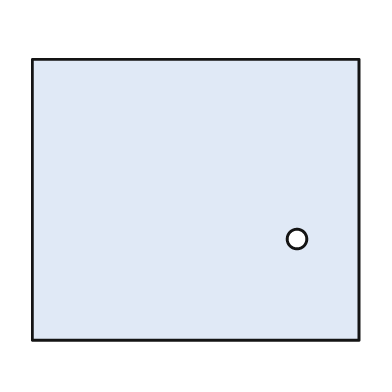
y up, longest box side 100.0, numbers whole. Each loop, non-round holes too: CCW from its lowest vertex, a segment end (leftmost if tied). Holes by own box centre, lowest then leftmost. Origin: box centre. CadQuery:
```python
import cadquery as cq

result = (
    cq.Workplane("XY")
    .moveTo(-50.0, -43.0)
    .lineTo(50.0, -43.0)
    .lineTo(50.0, 43.0)
    .lineTo(-50.0, 43.0)
    .close()
    .moveTo(31.0, -12.0)
    .circle(3.0)
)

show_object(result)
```